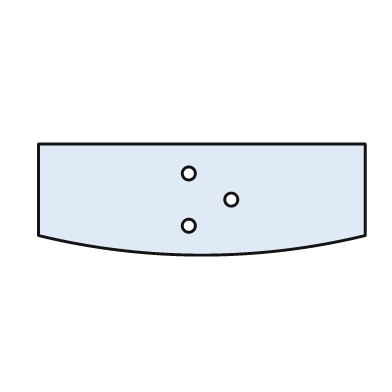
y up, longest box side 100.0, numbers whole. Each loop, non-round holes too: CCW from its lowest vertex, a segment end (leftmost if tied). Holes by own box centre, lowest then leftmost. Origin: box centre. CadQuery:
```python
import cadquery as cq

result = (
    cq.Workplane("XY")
    .moveTo(-50.0, -11.0)
    .threePointArc((0.0, -17.0), (50.0, -11.0))
    .lineTo(50.0, 17.0)
    .lineTo(-50.0, 17.0)
    .close()
    .moveTo(-4.0, -8.0)
    .circle(2.0)
    .moveTo(9.0, 0.0)
    .circle(2.0)
    .moveTo(-4.0, 8.0)
    .circle(2.0)
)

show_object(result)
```